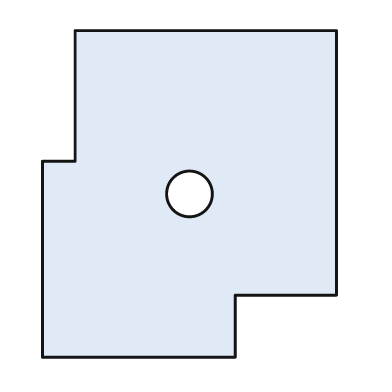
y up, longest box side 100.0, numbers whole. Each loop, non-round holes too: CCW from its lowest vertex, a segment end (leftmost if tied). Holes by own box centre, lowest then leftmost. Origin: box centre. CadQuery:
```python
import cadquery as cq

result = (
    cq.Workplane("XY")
    .moveTo(-45.0, -50.0)
    .lineTo(14.0, -50.0)
    .lineTo(14.0, -31.0)
    .lineTo(45.0, -31.0)
    .lineTo(45.0, 50.0)
    .lineTo(-35.0, 50.0)
    .lineTo(-35.0, 10.0)
    .lineTo(-45.0, 10.0)
    .close()
    .moveTo(0.0, 0.0)
    .circle(7.0)
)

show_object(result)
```